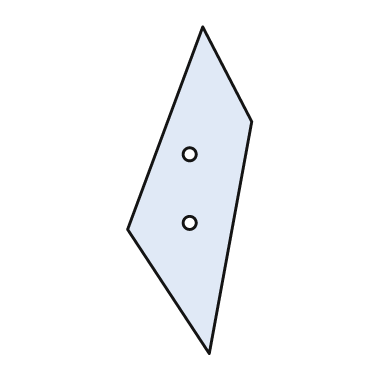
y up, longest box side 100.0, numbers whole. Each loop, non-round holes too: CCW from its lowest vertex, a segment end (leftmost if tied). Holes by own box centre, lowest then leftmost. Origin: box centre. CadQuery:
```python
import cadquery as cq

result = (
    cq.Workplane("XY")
    .moveTo(6.0, -50.0)
    .lineTo(19.0, 21.0)
    .lineTo(4.0, 50.0)
    .lineTo(-19.0, -12.0)
    .close()
    .moveTo(0.0, -10.0)
    .circle(2.0)
    .moveTo(0.0, 11.0)
    .circle(2.0)
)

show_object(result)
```